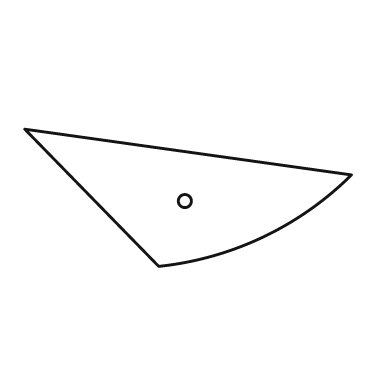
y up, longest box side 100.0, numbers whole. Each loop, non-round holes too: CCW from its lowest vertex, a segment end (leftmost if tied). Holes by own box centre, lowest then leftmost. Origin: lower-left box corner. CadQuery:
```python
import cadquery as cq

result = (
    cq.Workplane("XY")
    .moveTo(41.0, 0.0)
    .threePointArc((73.0, 9.0), (100.0, 28.0))
    .lineTo(0.0, 42.0)
    .close()
    .moveTo(49.0, 20.0)
    .circle(2.0)
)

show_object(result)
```